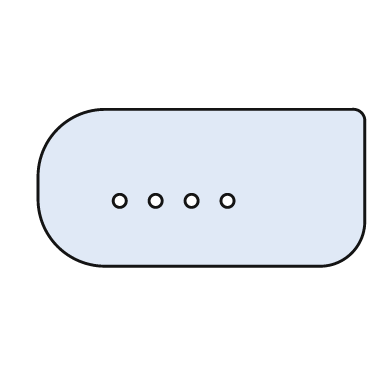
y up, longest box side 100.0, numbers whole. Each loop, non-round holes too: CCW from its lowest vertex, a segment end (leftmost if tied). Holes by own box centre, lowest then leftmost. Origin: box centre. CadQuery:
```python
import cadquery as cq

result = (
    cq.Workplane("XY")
    .moveTo(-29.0, -24.0)
    .lineTo(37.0, -24.0)
    .threePointArc((46.0, -20.0), (50.0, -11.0))
    .lineTo(50.0, 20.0)
    .threePointArc((49.0, 23.0), (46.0, 24.0))
    .lineTo(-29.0, 24.0)
    .threePointArc((-44.0, 18.0), (-50.0, 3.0))
    .lineTo(-50.0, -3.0)
    .threePointArc((-44.0, -18.0), (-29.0, -24.0))
    .close()
    .moveTo(-25.0, -4.0)
    .circle(2.0)
    .moveTo(-14.0, -4.0)
    .circle(2.0)
    .moveTo(-3.0, -4.0)
    .circle(2.0)
    .moveTo(8.0, -4.0)
    .circle(2.0)
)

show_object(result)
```